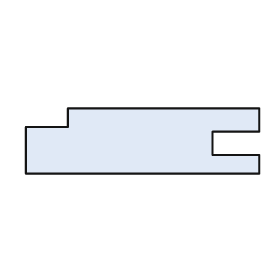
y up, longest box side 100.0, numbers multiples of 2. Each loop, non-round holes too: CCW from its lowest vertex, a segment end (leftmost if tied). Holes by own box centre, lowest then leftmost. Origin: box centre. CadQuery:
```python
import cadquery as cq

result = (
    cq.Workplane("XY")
    .moveTo(-50.0, -14.0)
    .lineTo(50.0, -14.0)
    .lineTo(50.0, -6.0)
    .lineTo(30.0, -6.0)
    .lineTo(30.0, 4.0)
    .lineTo(50.0, 4.0)
    .lineTo(50.0, 14.0)
    .lineTo(-32.0, 14.0)
    .lineTo(-32.0, 6.0)
    .lineTo(-50.0, 6.0)
    .close()
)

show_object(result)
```